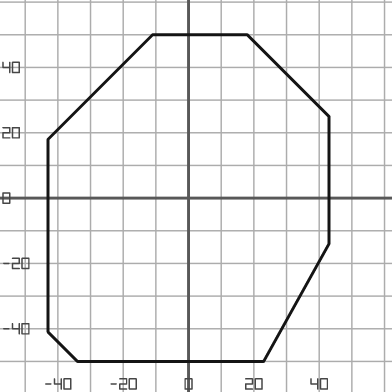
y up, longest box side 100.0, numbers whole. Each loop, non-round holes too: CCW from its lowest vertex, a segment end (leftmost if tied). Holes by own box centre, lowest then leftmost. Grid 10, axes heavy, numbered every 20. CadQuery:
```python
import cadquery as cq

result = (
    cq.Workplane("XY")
    .moveTo(-34.0, -50.0)
    .lineTo(23.0, -50.0)
    .lineTo(43.0, -14.0)
    .lineTo(43.0, 25.0)
    .lineTo(18.0, 50.0)
    .lineTo(-11.0, 50.0)
    .lineTo(-43.0, 18.0)
    .lineTo(-43.0, -41.0)
    .close()
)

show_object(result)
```